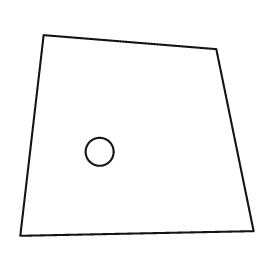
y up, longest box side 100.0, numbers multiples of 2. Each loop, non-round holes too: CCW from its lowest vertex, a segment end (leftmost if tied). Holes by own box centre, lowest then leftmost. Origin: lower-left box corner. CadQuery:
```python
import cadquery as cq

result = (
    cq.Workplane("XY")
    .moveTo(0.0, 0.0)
    .lineTo(100.0, 2.0)
    .lineTo(84.0, 80.0)
    .lineTo(10.0, 86.0)
    .close()
    .moveTo(34.0, 36.0)
    .circle(6.0)
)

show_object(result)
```